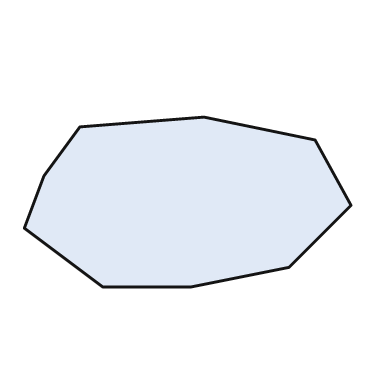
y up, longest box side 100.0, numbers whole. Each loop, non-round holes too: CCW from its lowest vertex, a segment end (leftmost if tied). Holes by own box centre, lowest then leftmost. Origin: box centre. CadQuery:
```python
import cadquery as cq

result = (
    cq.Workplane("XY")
    .moveTo(-26.0, -26.0)
    .lineTo(1.0, -26.0)
    .lineTo(31.0, -20.0)
    .lineTo(50.0, -1.0)
    .lineTo(39.0, 19.0)
    .lineTo(5.0, 26.0)
    .lineTo(-33.0, 23.0)
    .lineTo(-44.0, 8.0)
    .lineTo(-50.0, -8.0)
    .close()
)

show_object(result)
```